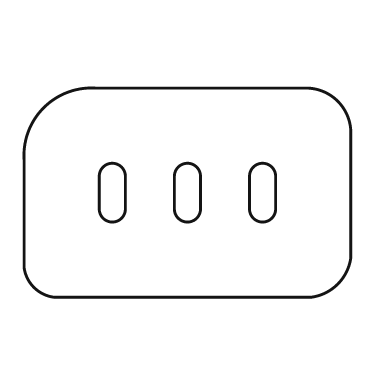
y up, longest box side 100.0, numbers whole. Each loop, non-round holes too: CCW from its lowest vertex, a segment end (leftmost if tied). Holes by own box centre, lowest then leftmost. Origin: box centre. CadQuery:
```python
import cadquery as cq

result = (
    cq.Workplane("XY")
    .moveTo(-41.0, -32.0)
    .lineTo(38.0, -32.0)
    .threePointArc((46.0, -28.0), (50.0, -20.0))
    .lineTo(50.0, 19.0)
    .threePointArc((46.0, 28.0), (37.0, 32.0))
    .lineTo(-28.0, 32.0)
    .threePointArc((-44.0, 26.0), (-50.0, 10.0))
    .lineTo(-50.0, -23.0)
    .threePointArc((-47.0, -29.0), (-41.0, -32.0))
    .close()
    .moveTo(-27.0, -5.0)
    .threePointArc((-23.0, -9.0), (-19.0, -5.0))
    .lineTo(-19.0, 5.0)
    .threePointArc((-23.0, 9.0), (-27.0, 5.0))
    .close()
    .moveTo(-4.0, -5.0)
    .threePointArc((0.0, -9.0), (4.0, -5.0))
    .lineTo(4.0, 5.0)
    .threePointArc((0.0, 9.0), (-4.0, 5.0))
    .close()
    .moveTo(19.0, -5.0)
    .threePointArc((23.0, -9.0), (27.0, -5.0))
    .lineTo(27.0, 5.0)
    .threePointArc((23.0, 9.0), (19.0, 5.0))
    .close()
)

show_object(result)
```